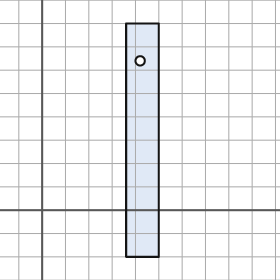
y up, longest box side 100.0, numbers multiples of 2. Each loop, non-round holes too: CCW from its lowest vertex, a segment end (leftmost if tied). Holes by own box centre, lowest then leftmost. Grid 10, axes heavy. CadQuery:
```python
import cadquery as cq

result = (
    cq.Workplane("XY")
    .moveTo(36.0, -20.0)
    .lineTo(50.0, -20.0)
    .lineTo(50.0, 80.0)
    .lineTo(36.0, 80.0)
    .close()
    .moveTo(42.0, 64.0)
    .circle(2.0)
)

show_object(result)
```